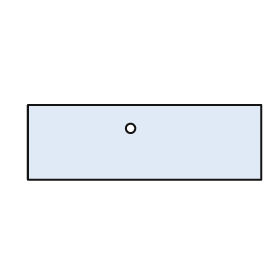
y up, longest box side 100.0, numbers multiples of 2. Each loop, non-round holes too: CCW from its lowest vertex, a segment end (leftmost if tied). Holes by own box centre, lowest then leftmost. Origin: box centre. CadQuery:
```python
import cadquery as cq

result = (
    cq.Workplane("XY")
    .moveTo(-50.0, -16.0)
    .lineTo(50.0, -16.0)
    .lineTo(50.0, 16.0)
    .lineTo(-50.0, 16.0)
    .close()
    .moveTo(-6.0, 6.0)
    .circle(2.0)
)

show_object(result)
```